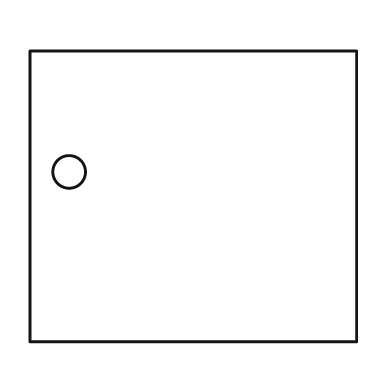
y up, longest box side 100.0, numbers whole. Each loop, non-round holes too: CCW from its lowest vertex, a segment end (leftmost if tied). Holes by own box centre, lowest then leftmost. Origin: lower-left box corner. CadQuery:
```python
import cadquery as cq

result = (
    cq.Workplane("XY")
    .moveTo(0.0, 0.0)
    .lineTo(100.0, 0.0)
    .lineTo(100.0, 89.0)
    .lineTo(0.0, 89.0)
    .close()
    .moveTo(12.0, 52.0)
    .circle(5.0)
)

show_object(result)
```